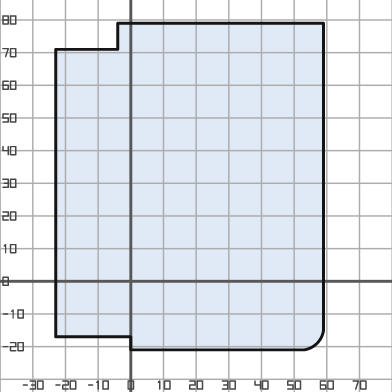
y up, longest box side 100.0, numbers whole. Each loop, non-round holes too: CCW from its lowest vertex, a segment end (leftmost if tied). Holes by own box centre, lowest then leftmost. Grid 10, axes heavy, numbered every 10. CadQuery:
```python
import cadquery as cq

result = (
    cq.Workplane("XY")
    .moveTo(0.0, -21.0)
    .lineTo(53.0, -21.0)
    .threePointArc((57.0, -19.0), (59.0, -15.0))
    .lineTo(59.0, 79.0)
    .lineTo(-4.0, 79.0)
    .lineTo(-4.0, 71.0)
    .lineTo(-23.0, 71.0)
    .lineTo(-23.0, -17.0)
    .lineTo(0.0, -17.0)
    .close()
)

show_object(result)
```